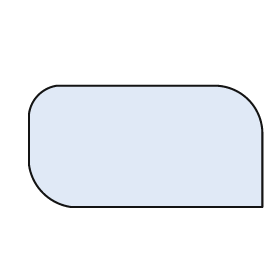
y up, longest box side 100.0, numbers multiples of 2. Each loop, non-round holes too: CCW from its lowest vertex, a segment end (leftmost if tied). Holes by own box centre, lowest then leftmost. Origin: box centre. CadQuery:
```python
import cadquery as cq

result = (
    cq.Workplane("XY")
    .moveTo(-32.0, -26.0)
    .lineTo(50.0, -26.0)
    .lineTo(50.0, 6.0)
    .threePointArc((44.0, 20.0), (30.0, 26.0))
    .lineTo(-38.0, 26.0)
    .threePointArc((-46.0, 22.0), (-50.0, 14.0))
    .lineTo(-50.0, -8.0)
    .threePointArc((-44.0, -20.0), (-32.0, -26.0))
    .close()
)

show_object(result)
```